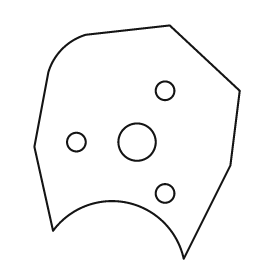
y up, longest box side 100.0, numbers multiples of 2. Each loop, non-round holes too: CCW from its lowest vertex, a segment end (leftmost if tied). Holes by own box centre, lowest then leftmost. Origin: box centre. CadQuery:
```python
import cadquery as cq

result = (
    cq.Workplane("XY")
    .moveTo(20.0, -50.0)
    .lineTo(40.0, -10.0)
    .lineTo(44.0, 22.0)
    .lineTo(14.0, 50.0)
    .lineTo(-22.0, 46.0)
    .threePointArc((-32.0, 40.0), (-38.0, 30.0))
    .lineTo(-44.0, -2.0)
    .lineTo(-36.0, -38.0)
    .threePointArc((-4.0, -26.0), (20.0, -50.0))
    .close()
    .moveTo(12.0, -22.0)
    .circle(4.0)
    .moveTo(-26.0, 0.0)
    .circle(4.0)
    .moveTo(0.0, 0.0)
    .circle(8.0)
    .moveTo(12.0, 22.0)
    .circle(4.0)
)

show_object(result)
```